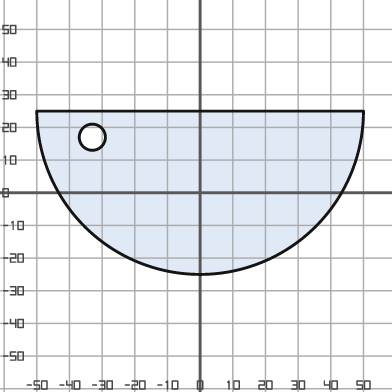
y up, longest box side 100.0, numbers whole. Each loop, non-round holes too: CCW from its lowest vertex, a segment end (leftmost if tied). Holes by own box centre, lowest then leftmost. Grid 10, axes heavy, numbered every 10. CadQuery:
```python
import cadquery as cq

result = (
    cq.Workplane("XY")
    .moveTo(-50.0, 25.0)
    .threePointArc((0.0, -25.0), (50.0, 25.0))
    .close()
    .moveTo(-33.0, 17.0)
    .circle(4.0)
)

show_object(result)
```